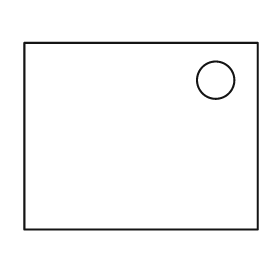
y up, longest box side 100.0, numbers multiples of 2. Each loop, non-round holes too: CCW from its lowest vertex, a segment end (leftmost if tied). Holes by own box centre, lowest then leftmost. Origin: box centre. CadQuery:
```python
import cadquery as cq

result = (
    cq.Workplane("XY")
    .moveTo(-50.0, -40.0)
    .lineTo(50.0, -40.0)
    .lineTo(50.0, 40.0)
    .lineTo(-50.0, 40.0)
    .close()
    .moveTo(32.0, 24.0)
    .circle(8.0)
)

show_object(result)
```